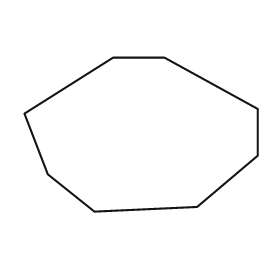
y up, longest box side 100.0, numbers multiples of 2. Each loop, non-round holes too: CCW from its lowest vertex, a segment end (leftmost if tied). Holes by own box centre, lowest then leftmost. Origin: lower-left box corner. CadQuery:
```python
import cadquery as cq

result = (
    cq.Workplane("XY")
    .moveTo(30.0, 0.0)
    .lineTo(74.0, 2.0)
    .lineTo(100.0, 24.0)
    .lineTo(100.0, 44.0)
    .lineTo(60.0, 66.0)
    .lineTo(38.0, 66.0)
    .lineTo(0.0, 42.0)
    .lineTo(10.0, 16.0)
    .close()
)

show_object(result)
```